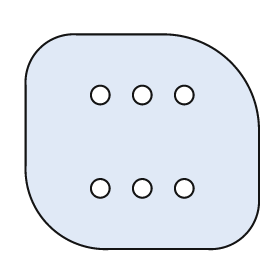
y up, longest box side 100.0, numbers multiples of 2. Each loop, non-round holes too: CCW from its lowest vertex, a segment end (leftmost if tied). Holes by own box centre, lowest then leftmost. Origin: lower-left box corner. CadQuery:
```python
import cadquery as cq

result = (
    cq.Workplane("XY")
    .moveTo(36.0, 0.0)
    .lineTo(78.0, 0.0)
    .threePointArc((94.0, 6.0), (100.0, 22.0))
    .lineTo(100.0, 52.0)
    .threePointArc((88.0, 80.0), (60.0, 92.0))
    .lineTo(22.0, 92.0)
    .threePointArc((6.0, 86.0), (0.0, 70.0))
    .lineTo(0.0, 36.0)
    .threePointArc((10.0, 10.0), (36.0, 0.0))
    .close()
    .moveTo(32.0, 26.0)
    .circle(4.0)
    .moveTo(50.0, 26.0)
    .circle(4.0)
    .moveTo(68.0, 26.0)
    .circle(4.0)
    .moveTo(32.0, 66.0)
    .circle(4.0)
    .moveTo(50.0, 66.0)
    .circle(4.0)
    .moveTo(68.0, 66.0)
    .circle(4.0)
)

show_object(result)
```